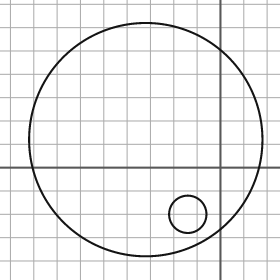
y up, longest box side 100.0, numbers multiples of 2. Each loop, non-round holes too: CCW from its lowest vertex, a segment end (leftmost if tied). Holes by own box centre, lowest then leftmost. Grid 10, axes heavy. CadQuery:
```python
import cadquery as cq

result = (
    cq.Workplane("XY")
    .moveTo(-32.0, 12.0)
    .circle(50.0)
    .moveTo(-14.0, -20.0)
    .circle(8.0)
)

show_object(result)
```